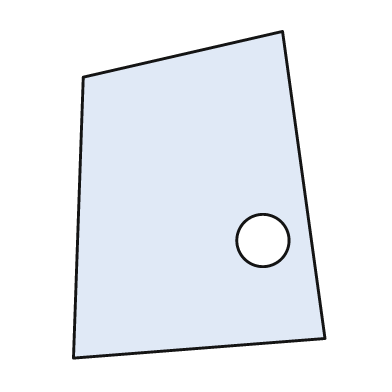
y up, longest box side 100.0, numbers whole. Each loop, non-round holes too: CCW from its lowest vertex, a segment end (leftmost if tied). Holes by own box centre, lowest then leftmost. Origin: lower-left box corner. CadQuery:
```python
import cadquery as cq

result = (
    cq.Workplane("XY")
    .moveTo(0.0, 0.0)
    .lineTo(77.0, 6.0)
    .lineTo(64.0, 100.0)
    .lineTo(3.0, 86.0)
    .close()
    .moveTo(58.0, 36.0)
    .circle(8.0)
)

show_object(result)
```